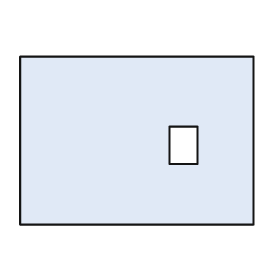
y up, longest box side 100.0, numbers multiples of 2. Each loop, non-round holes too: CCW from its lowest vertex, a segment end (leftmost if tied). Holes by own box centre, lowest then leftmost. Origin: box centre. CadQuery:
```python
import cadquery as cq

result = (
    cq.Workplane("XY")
    .moveTo(-50.0, -36.0)
    .lineTo(50.0, -36.0)
    .lineTo(50.0, 36.0)
    .lineTo(-50.0, 36.0)
    .close()
    .moveTo(14.0, -10.0)
    .lineTo(26.0, -10.0)
    .lineTo(26.0, 6.0)
    .lineTo(14.0, 6.0)
    .close()
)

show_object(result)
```